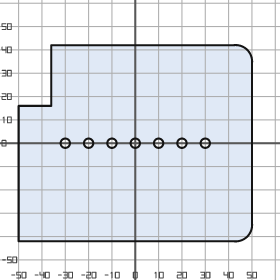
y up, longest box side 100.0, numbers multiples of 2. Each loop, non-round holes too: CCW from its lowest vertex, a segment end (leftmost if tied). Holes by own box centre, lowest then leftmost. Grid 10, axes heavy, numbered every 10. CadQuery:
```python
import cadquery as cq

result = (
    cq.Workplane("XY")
    .moveTo(-50.0, -42.0)
    .lineTo(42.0, -42.0)
    .threePointArc((48.0, -40.0), (50.0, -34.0))
    .lineTo(50.0, 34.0)
    .threePointArc((48.0, 40.0), (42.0, 42.0))
    .lineTo(-36.0, 42.0)
    .lineTo(-36.0, 16.0)
    .lineTo(-50.0, 16.0)
    .close()
    .moveTo(-30.0, 0.0)
    .circle(2.0)
    .moveTo(-20.0, 0.0)
    .circle(2.0)
    .moveTo(-10.0, 0.0)
    .circle(2.0)
    .moveTo(0.0, 0.0)
    .circle(2.0)
    .moveTo(10.0, 0.0)
    .circle(2.0)
    .moveTo(20.0, 0.0)
    .circle(2.0)
    .moveTo(30.0, 0.0)
    .circle(2.0)
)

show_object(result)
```